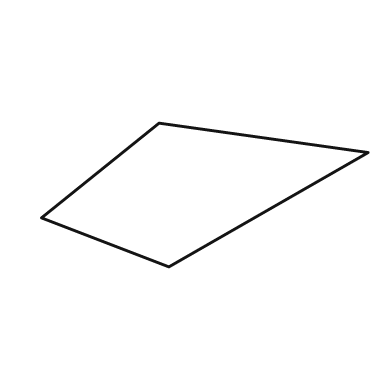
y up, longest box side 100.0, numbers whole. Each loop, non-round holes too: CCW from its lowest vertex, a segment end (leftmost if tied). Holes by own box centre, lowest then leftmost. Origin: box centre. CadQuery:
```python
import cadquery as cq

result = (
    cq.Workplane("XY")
    .moveTo(-11.0, -22.0)
    .lineTo(50.0, 13.0)
    .lineTo(-14.0, 22.0)
    .lineTo(-50.0, -7.0)
    .close()
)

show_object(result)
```